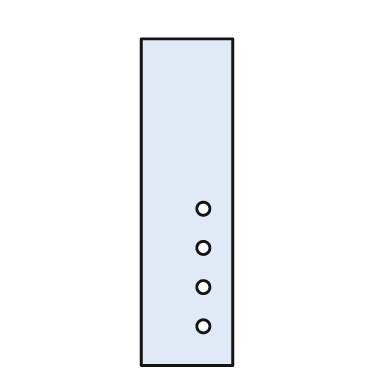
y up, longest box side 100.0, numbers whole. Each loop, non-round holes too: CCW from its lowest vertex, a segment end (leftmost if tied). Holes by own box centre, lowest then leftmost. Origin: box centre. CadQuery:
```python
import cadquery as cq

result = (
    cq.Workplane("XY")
    .moveTo(-14.0, -50.0)
    .lineTo(14.0, -50.0)
    .lineTo(14.0, 50.0)
    .lineTo(-14.0, 50.0)
    .close()
    .moveTo(5.0, -38.0)
    .circle(2.0)
    .moveTo(5.0, -26.0)
    .circle(2.0)
    .moveTo(5.0, -14.0)
    .circle(2.0)
    .moveTo(5.0, -2.0)
    .circle(2.0)
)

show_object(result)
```